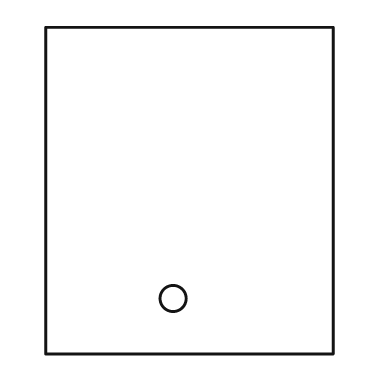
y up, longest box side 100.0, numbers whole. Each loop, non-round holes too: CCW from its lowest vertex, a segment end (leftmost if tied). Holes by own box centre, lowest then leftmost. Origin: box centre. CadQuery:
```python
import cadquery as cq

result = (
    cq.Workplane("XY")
    .moveTo(-44.0, -50.0)
    .lineTo(44.0, -50.0)
    .lineTo(44.0, 50.0)
    .lineTo(-44.0, 50.0)
    .close()
    .moveTo(-5.0, -33.0)
    .circle(4.0)
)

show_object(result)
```